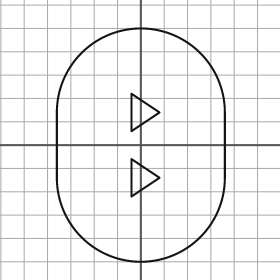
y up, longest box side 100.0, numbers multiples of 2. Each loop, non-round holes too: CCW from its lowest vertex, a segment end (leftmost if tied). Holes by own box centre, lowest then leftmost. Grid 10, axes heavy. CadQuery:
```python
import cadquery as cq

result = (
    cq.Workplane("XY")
    .moveTo(-36.0, -14.0)
    .threePointArc((0.0, -50.0), (36.0, -14.0))
    .lineTo(36.0, 14.0)
    .threePointArc((0.0, 50.0), (-36.0, 14.0))
    .close()
    .moveTo(-4.0, -22.0)
    .lineTo(8.0, -14.0)
    .lineTo(-4.0, -6.0)
    .close()
    .moveTo(-4.0, 6.0)
    .lineTo(8.0, 14.0)
    .lineTo(-4.0, 22.0)
    .close()
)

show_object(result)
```